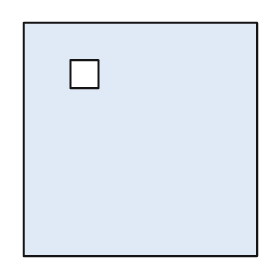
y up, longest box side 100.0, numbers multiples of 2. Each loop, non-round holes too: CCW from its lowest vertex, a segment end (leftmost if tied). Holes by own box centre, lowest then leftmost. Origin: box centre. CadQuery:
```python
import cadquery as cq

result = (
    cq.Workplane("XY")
    .moveTo(-50.0, -50.0)
    .lineTo(50.0, -50.0)
    .lineTo(50.0, 50.0)
    .lineTo(-50.0, 50.0)
    .close()
    .moveTo(-30.0, 22.0)
    .lineTo(-18.0, 22.0)
    .lineTo(-18.0, 34.0)
    .lineTo(-30.0, 34.0)
    .close()
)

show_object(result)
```